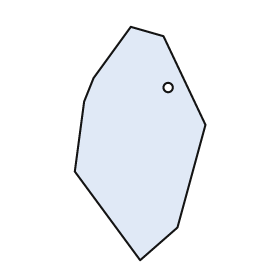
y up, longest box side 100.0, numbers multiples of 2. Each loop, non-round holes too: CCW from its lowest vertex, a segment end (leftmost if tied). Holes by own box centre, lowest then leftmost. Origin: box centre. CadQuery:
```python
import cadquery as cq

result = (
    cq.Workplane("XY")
    .moveTo(0.0, -50.0)
    .lineTo(16.0, -36.0)
    .lineTo(28.0, 8.0)
    .lineTo(10.0, 46.0)
    .lineTo(-4.0, 50.0)
    .lineTo(-20.0, 28.0)
    .lineTo(-24.0, 18.0)
    .lineTo(-28.0, -12.0)
    .close()
    .moveTo(12.0, 24.0)
    .circle(2.0)
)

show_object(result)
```